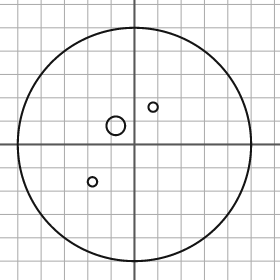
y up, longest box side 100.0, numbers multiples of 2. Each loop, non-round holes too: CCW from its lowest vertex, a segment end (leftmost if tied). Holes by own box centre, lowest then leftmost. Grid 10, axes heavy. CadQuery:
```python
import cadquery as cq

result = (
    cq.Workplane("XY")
    .moveTo(0.0, 0.0)
    .circle(50.0)
    .moveTo(-18.0, -16.0)
    .circle(2.0)
    .moveTo(-8.0, 8.0)
    .circle(4.0)
    .moveTo(8.0, 16.0)
    .circle(2.0)
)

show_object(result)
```